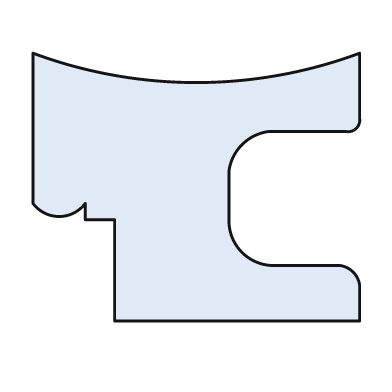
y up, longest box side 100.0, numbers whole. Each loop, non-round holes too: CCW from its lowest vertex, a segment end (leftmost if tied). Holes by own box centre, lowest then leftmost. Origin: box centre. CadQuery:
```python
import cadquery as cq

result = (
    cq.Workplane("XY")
    .moveTo(-25.0, -41.0)
    .lineTo(50.0, -41.0)
    .lineTo(50.0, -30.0)
    .threePointArc((48.0, -26.0), (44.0, -24.0))
    .lineTo(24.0, -24.0)
    .threePointArc((14.0, -20.0), (10.0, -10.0))
    .lineTo(10.0, 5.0)
    .threePointArc((14.0, 13.0), (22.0, 17.0))
    .lineTo(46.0, 17.0)
    .threePointArc((49.0, 18.0), (50.0, 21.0))
    .lineTo(50.0, 41.0)
    .threePointArc((0.0, 32.0), (-50.0, 41.0))
    .lineTo(-50.0, -5.0)
    .threePointArc((-42.0, -9.0), (-34.0, -5.0))
    .lineTo(-34.0, -10.0)
    .lineTo(-25.0, -10.0)
    .close()
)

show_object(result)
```